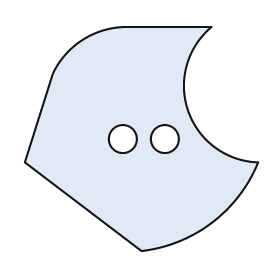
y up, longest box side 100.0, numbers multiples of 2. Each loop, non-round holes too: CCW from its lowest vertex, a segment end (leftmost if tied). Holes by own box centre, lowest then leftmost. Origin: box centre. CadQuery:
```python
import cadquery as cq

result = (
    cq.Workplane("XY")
    .moveTo(0.0, -48.0)
    .threePointArc((30.0, -36.0), (50.0, -10.0))
    .threePointArc((20.0, 12.0), (30.0, 48.0))
    .lineTo(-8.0, 48.0)
    .threePointArc((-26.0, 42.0), (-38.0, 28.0))
    .lineTo(-50.0, -10.0)
    .close()
    .moveTo(-8.0, 0.0)
    .circle(6.0)
    .moveTo(10.0, 0.0)
    .circle(6.0)
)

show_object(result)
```